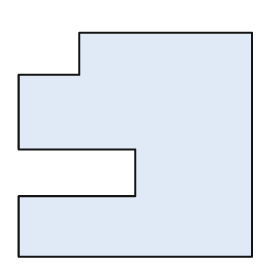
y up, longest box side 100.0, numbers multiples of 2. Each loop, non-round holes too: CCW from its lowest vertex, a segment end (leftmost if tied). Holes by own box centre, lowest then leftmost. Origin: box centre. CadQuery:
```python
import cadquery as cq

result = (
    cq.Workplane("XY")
    .moveTo(-50.0, -48.0)
    .lineTo(50.0, -48.0)
    .lineTo(50.0, 48.0)
    .lineTo(-24.0, 48.0)
    .lineTo(-24.0, 30.0)
    .lineTo(-50.0, 30.0)
    .lineTo(-50.0, -2.0)
    .lineTo(0.0, -2.0)
    .lineTo(0.0, -22.0)
    .lineTo(-50.0, -22.0)
    .close()
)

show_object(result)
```